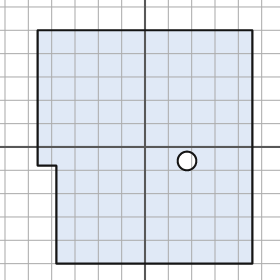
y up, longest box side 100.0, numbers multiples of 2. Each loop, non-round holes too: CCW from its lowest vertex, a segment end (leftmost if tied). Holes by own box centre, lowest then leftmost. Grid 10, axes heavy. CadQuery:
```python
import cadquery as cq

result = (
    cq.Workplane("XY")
    .moveTo(-38.0, -50.0)
    .lineTo(46.0, -50.0)
    .lineTo(46.0, 50.0)
    .lineTo(-46.0, 50.0)
    .lineTo(-46.0, -8.0)
    .lineTo(-38.0, -8.0)
    .close()
    .moveTo(18.0, -6.0)
    .circle(4.0)
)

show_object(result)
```